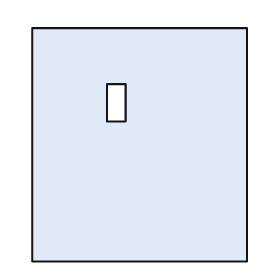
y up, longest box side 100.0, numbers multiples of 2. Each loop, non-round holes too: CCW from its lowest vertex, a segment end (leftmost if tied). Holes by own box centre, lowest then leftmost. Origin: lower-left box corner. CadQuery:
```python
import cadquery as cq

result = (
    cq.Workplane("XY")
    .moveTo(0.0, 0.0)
    .lineTo(92.0, 0.0)
    .lineTo(92.0, 100.0)
    .lineTo(0.0, 100.0)
    .close()
    .moveTo(32.0, 60.0)
    .lineTo(40.0, 60.0)
    .lineTo(40.0, 76.0)
    .lineTo(32.0, 76.0)
    .close()
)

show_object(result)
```